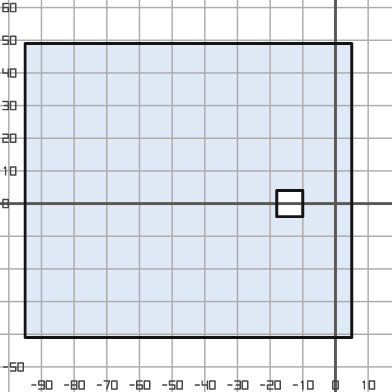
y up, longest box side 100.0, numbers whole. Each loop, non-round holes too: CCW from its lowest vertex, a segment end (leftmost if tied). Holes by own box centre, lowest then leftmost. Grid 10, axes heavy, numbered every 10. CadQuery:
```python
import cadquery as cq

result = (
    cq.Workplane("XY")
    .moveTo(-95.0, -41.0)
    .lineTo(5.0, -41.0)
    .lineTo(5.0, 49.0)
    .lineTo(-95.0, 49.0)
    .close()
    .moveTo(-18.0, -4.0)
    .lineTo(-10.0, -4.0)
    .lineTo(-10.0, 4.0)
    .lineTo(-18.0, 4.0)
    .close()
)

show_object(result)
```